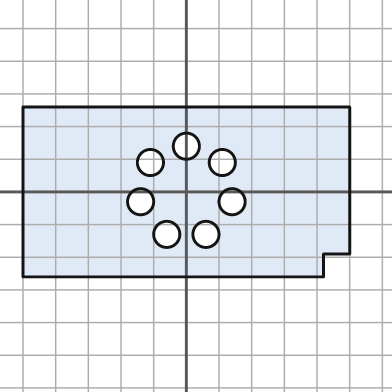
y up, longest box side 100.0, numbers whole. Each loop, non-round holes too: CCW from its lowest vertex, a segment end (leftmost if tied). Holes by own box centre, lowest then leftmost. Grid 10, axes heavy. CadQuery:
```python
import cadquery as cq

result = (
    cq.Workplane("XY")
    .moveTo(-50.0, -26.0)
    .lineTo(42.0, -26.0)
    .lineTo(42.0, -19.0)
    .lineTo(50.0, -19.0)
    .lineTo(50.0, 26.0)
    .lineTo(-50.0, 26.0)
    .close()
    .moveTo(-6.0, -13.0)
    .circle(4.0)
    .moveTo(6.0, -13.0)
    .circle(4.0)
    .moveTo(-14.0, -3.0)
    .circle(4.0)
    .moveTo(14.0, -3.0)
    .circle(4.0)
    .moveTo(-11.0, 9.0)
    .circle(4.0)
    .moveTo(11.0, 9.0)
    .circle(4.0)
    .moveTo(0.0, 14.0)
    .circle(4.0)
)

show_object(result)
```